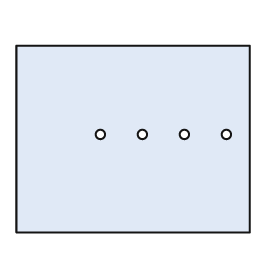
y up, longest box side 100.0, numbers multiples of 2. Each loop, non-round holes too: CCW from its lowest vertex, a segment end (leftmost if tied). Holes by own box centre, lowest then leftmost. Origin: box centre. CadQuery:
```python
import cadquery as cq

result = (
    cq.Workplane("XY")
    .moveTo(-50.0, -40.0)
    .lineTo(50.0, -40.0)
    .lineTo(50.0, 40.0)
    .lineTo(-50.0, 40.0)
    .close()
    .moveTo(-14.0, 2.0)
    .circle(2.0)
    .moveTo(4.0, 2.0)
    .circle(2.0)
    .moveTo(22.0, 2.0)
    .circle(2.0)
    .moveTo(40.0, 2.0)
    .circle(2.0)
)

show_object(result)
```